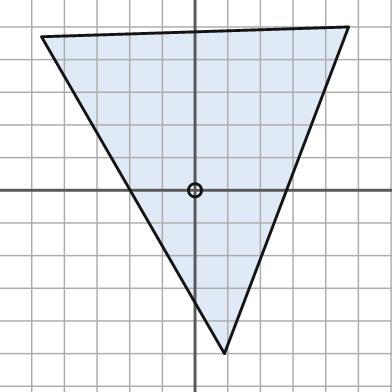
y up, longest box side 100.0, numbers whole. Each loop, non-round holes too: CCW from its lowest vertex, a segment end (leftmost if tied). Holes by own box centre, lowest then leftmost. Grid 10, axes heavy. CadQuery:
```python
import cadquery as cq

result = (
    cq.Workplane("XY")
    .moveTo(9.0, -50.0)
    .lineTo(47.0, 50.0)
    .lineTo(-47.0, 47.0)
    .close()
    .moveTo(0.0, 0.0)
    .circle(2.0)
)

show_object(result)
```